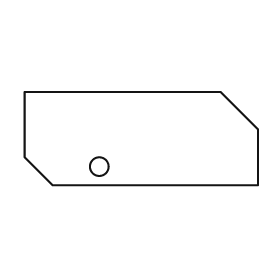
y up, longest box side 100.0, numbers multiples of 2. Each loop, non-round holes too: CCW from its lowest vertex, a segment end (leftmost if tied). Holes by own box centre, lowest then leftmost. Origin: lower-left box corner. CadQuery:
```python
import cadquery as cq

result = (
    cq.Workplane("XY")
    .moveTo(12.0, 0.0)
    .lineTo(100.0, 0.0)
    .lineTo(100.0, 24.0)
    .lineTo(84.0, 40.0)
    .lineTo(0.0, 40.0)
    .lineTo(0.0, 12.0)
    .close()
    .moveTo(32.0, 8.0)
    .circle(4.0)
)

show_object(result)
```